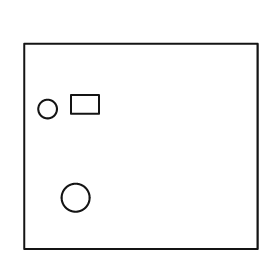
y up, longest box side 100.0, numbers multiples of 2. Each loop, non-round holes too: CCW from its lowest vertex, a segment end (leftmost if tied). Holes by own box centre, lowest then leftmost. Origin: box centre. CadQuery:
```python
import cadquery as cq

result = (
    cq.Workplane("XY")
    .moveTo(-50.0, -44.0)
    .lineTo(50.0, -44.0)
    .lineTo(50.0, 44.0)
    .lineTo(-50.0, 44.0)
    .close()
    .moveTo(-28.0, -22.0)
    .circle(6.0)
    .moveTo(-40.0, 16.0)
    .circle(4.0)
    .moveTo(-30.0, 14.0)
    .lineTo(-18.0, 14.0)
    .lineTo(-18.0, 22.0)
    .lineTo(-30.0, 22.0)
    .close()
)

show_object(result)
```